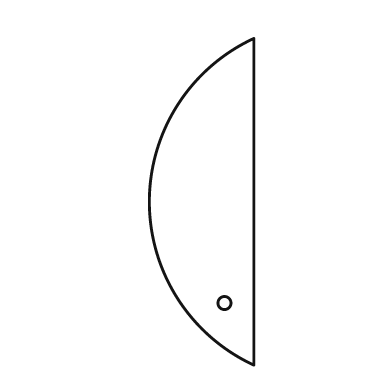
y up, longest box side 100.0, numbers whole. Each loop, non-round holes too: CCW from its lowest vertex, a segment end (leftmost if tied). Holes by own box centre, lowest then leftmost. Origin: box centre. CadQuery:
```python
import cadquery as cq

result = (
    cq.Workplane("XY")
    .moveTo(16.0, -50.0)
    .lineTo(16.0, 50.0)
    .threePointArc((-16.0, 0.0), (16.0, -50.0))
    .close()
    .moveTo(7.0, -31.0)
    .circle(2.0)
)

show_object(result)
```